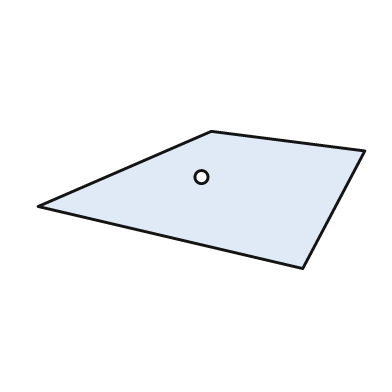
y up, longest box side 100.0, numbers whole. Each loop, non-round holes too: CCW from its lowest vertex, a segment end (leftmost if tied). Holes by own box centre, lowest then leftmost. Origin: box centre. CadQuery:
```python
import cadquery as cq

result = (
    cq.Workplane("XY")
    .moveTo(31.0, -21.0)
    .lineTo(50.0, 15.0)
    .lineTo(3.0, 21.0)
    .lineTo(-50.0, -2.0)
    .close()
    .moveTo(0.0, 7.0)
    .circle(2.0)
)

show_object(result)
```